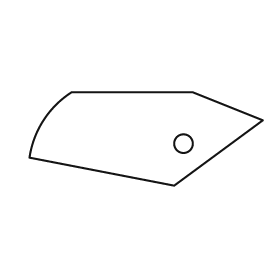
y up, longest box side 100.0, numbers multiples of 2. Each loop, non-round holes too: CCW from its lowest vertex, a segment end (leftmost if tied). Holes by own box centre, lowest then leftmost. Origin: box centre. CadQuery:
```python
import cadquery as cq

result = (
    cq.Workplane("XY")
    .moveTo(12.0, -20.0)
    .lineTo(50.0, 8.0)
    .lineTo(20.0, 20.0)
    .lineTo(-32.0, 20.0)
    .threePointArc((-44.0, 8.0), (-50.0, -8.0))
    .close()
    .moveTo(16.0, -2.0)
    .circle(4.0)
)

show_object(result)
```